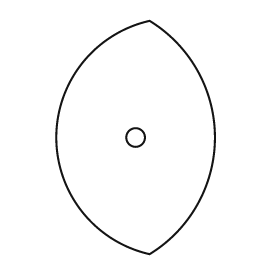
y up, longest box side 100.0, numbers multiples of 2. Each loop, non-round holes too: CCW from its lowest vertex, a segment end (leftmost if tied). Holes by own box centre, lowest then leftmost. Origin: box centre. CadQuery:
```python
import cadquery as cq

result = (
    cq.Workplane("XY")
    .moveTo(6.0, -50.0)
    .threePointArc((34.0, 0.0), (6.0, 50.0))
    .threePointArc((-34.0, 0.0), (6.0, -50.0))
    .close()
    .moveTo(0.0, 0.0)
    .circle(4.0)
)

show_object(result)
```